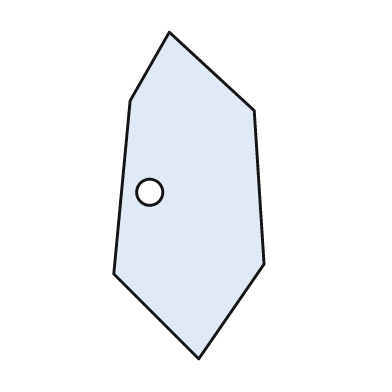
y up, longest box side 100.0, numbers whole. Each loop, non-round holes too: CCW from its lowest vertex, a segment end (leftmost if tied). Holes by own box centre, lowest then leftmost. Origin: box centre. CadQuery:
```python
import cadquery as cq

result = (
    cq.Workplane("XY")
    .moveTo(3.0, -50.0)
    .lineTo(23.0, -21.0)
    .lineTo(20.0, 26.0)
    .lineTo(-6.0, 50.0)
    .lineTo(-18.0, 29.0)
    .lineTo(-23.0, -24.0)
    .close()
    .moveTo(-12.0, 1.0)
    .circle(4.0)
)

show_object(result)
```